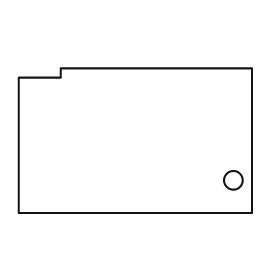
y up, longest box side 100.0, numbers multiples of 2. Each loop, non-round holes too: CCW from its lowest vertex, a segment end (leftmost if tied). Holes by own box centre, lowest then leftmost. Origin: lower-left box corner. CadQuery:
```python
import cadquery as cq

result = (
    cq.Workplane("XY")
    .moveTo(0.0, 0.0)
    .lineTo(100.0, 0.0)
    .lineTo(100.0, 62.0)
    .lineTo(18.0, 62.0)
    .lineTo(18.0, 58.0)
    .lineTo(0.0, 58.0)
    .close()
    .moveTo(92.0, 14.0)
    .circle(4.0)
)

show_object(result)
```